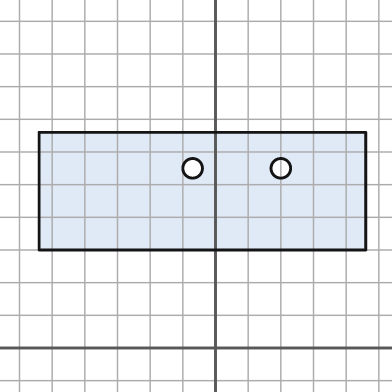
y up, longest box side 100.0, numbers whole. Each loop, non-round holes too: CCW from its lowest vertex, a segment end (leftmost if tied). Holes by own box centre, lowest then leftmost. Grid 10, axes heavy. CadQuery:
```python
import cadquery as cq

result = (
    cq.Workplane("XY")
    .moveTo(-54.0, 30.0)
    .lineTo(46.0, 30.0)
    .lineTo(46.0, 66.0)
    .lineTo(-54.0, 66.0)
    .close()
    .moveTo(-7.0, 55.0)
    .circle(3.0)
    .moveTo(20.0, 55.0)
    .circle(3.0)
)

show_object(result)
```